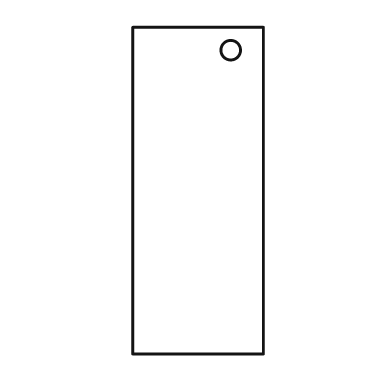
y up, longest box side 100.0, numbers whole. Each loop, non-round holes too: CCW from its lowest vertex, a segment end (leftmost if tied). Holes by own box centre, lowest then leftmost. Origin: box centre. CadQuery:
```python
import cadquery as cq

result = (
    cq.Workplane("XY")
    .moveTo(-20.0, -50.0)
    .lineTo(20.0, -50.0)
    .lineTo(20.0, 50.0)
    .lineTo(-20.0, 50.0)
    .close()
    .moveTo(10.0, 43.0)
    .circle(3.0)
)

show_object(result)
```